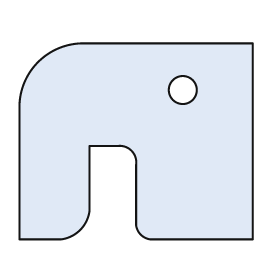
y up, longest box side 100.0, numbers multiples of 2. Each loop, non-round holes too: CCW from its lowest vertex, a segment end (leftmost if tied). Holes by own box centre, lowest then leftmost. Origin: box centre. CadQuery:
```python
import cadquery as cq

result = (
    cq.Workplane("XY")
    .moveTo(-50.0, -42.0)
    .lineTo(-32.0, -42.0)
    .threePointArc((-24.0, -38.0), (-20.0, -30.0))
    .lineTo(-20.0, -2.0)
    .lineTo(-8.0, -2.0)
    .threePointArc((-2.0, -4.0), (0.0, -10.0))
    .lineTo(0.0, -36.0)
    .threePointArc((2.0, -40.0), (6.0, -42.0))
    .lineTo(50.0, -42.0)
    .lineTo(50.0, 42.0)
    .lineTo(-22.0, 42.0)
    .threePointArc((-42.0, 34.0), (-50.0, 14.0))
    .close()
    .moveTo(20.0, 22.0)
    .circle(6.0)
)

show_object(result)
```